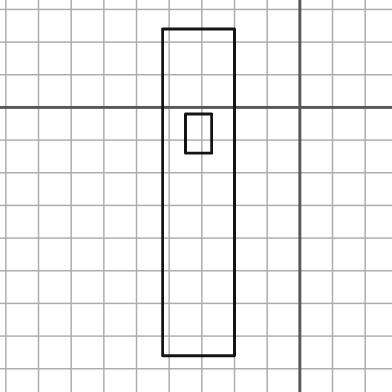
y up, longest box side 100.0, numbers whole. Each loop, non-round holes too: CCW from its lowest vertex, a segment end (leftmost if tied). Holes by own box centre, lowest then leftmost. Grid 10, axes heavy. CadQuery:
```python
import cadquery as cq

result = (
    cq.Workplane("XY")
    .moveTo(-42.0, -76.0)
    .lineTo(-20.0, -76.0)
    .lineTo(-20.0, 24.0)
    .lineTo(-42.0, 24.0)
    .close()
    .moveTo(-35.0, -14.0)
    .lineTo(-27.0, -14.0)
    .lineTo(-27.0, -2.0)
    .lineTo(-35.0, -2.0)
    .close()
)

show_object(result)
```